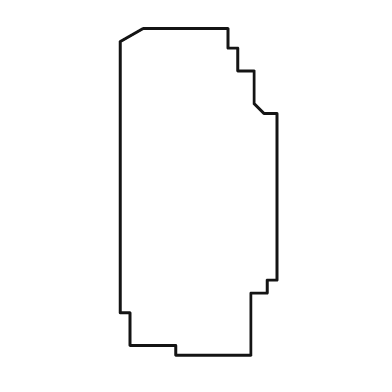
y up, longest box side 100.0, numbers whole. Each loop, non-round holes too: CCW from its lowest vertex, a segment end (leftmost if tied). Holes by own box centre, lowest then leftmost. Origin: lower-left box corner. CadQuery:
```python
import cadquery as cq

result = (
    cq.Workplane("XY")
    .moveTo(17.0, 0.0)
    .lineTo(40.0, 0.0)
    .lineTo(40.0, 19.0)
    .lineTo(45.0, 19.0)
    .lineTo(45.0, 23.0)
    .lineTo(48.0, 23.0)
    .lineTo(48.0, 74.0)
    .lineTo(44.0, 74.0)
    .lineTo(41.0, 77.0)
    .lineTo(41.0, 87.0)
    .lineTo(36.0, 87.0)
    .lineTo(36.0, 94.0)
    .lineTo(33.0, 94.0)
    .lineTo(33.0, 100.0)
    .lineTo(7.0, 100.0)
    .lineTo(0.0, 96.0)
    .lineTo(0.0, 13.0)
    .lineTo(3.0, 13.0)
    .lineTo(3.0, 3.0)
    .lineTo(17.0, 3.0)
    .close()
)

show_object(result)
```